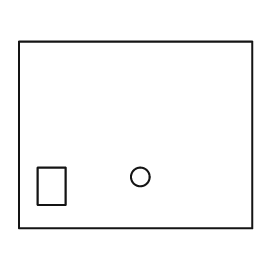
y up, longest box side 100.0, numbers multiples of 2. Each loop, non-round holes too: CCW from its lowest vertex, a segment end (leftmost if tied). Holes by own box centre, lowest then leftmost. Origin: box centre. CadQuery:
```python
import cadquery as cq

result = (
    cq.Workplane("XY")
    .moveTo(-50.0, -40.0)
    .lineTo(50.0, -40.0)
    .lineTo(50.0, 40.0)
    .lineTo(-50.0, 40.0)
    .close()
    .moveTo(-42.0, -30.0)
    .lineTo(-30.0, -30.0)
    .lineTo(-30.0, -14.0)
    .lineTo(-42.0, -14.0)
    .close()
    .moveTo(2.0, -18.0)
    .circle(4.0)
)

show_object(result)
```